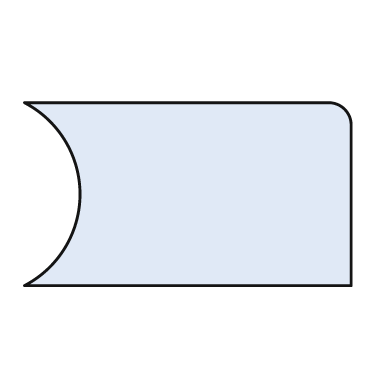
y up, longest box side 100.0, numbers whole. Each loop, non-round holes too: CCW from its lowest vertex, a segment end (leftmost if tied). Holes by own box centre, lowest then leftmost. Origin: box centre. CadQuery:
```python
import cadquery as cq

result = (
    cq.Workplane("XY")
    .moveTo(-50.0, -28.0)
    .lineTo(50.0, -28.0)
    .lineTo(50.0, 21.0)
    .threePointArc((48.0, 26.0), (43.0, 28.0))
    .lineTo(-50.0, 28.0)
    .threePointArc((-33.0, 0.0), (-50.0, -28.0))
    .close()
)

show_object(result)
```